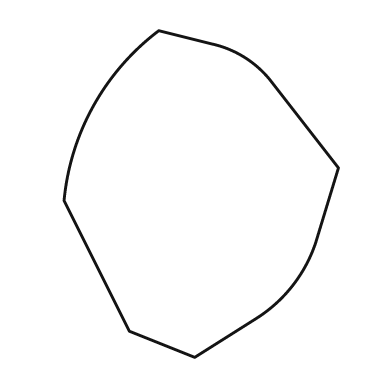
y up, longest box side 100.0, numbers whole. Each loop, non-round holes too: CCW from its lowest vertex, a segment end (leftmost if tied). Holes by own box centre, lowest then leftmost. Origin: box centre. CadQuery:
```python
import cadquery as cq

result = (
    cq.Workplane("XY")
    .moveTo(-2.0, -50.0)
    .lineTo(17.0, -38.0)
    .threePointArc((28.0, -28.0), (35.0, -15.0))
    .lineTo(42.0, 8.0)
    .lineTo(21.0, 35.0)
    .threePointArc((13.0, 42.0), (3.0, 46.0))
    .lineTo(-13.0, 50.0)
    .threePointArc((-33.0, 27.0), (-42.0, -2.0))
    .lineTo(-22.0, -42.0)
    .close()
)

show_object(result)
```